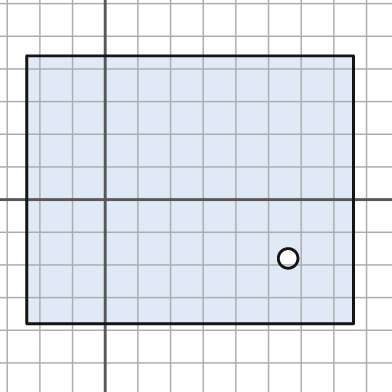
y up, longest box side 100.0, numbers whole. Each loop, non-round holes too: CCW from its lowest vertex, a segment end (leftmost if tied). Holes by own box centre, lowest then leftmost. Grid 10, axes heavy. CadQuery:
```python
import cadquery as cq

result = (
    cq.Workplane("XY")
    .moveTo(-24.0, -38.0)
    .lineTo(76.0, -38.0)
    .lineTo(76.0, 44.0)
    .lineTo(-24.0, 44.0)
    .close()
    .moveTo(56.0, -18.0)
    .circle(3.0)
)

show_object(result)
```